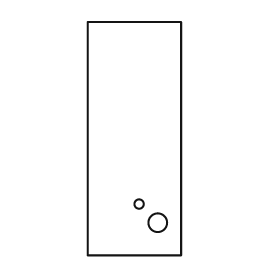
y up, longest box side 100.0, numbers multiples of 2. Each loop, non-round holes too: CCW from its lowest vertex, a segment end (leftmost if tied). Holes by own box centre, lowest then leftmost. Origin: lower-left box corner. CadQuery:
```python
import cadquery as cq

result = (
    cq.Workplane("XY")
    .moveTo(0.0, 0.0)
    .lineTo(40.0, 0.0)
    .lineTo(40.0, 100.0)
    .lineTo(0.0, 100.0)
    .close()
    .moveTo(30.0, 14.0)
    .circle(4.0)
    .moveTo(22.0, 22.0)
    .circle(2.0)
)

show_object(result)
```